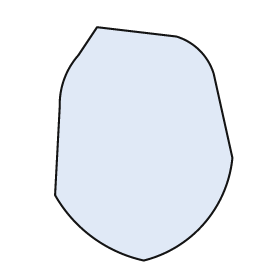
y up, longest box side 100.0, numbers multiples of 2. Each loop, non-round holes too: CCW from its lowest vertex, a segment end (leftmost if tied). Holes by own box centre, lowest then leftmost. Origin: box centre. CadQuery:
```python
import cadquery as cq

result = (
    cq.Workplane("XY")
    .moveTo(0.0, -50.0)
    .threePointArc((26.0, -34.0), (38.0, -6.0))
    .lineTo(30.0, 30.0)
    .threePointArc((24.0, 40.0), (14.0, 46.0))
    .lineTo(-20.0, 50.0)
    .lineTo(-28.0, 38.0)
    .threePointArc((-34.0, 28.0), (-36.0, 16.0))
    .lineTo(-38.0, -22.0)
    .threePointArc((-22.0, -40.0), (0.0, -50.0))
    .close()
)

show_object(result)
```